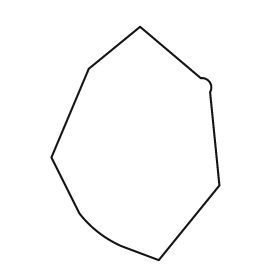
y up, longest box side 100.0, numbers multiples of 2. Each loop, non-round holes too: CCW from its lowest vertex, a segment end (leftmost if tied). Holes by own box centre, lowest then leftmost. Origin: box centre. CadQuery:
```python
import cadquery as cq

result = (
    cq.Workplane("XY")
    .moveTo(10.0, -50.0)
    .lineTo(36.0, -18.0)
    .lineTo(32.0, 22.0)
    .threePointArc((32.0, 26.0), (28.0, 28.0))
    .lineTo(2.0, 50.0)
    .lineTo(-20.0, 32.0)
    .lineTo(-36.0, -6.0)
    .lineTo(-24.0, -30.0)
    .threePointArc((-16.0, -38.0), (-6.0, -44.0))
    .close()
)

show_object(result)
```